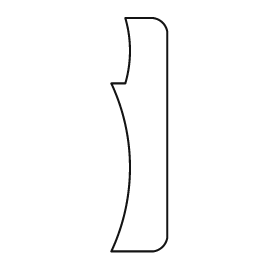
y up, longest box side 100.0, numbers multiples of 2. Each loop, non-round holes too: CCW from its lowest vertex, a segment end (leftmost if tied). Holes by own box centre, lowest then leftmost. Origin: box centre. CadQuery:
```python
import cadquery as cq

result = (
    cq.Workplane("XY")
    .moveTo(-12.0, -50.0)
    .lineTo(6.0, -50.0)
    .threePointArc((10.0, -48.0), (12.0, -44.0))
    .lineTo(12.0, 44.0)
    .threePointArc((10.0, 48.0), (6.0, 50.0))
    .lineTo(-6.0, 50.0)
    .threePointArc((-4.0, 36.0), (-6.0, 22.0))
    .lineTo(-12.0, 22.0)
    .threePointArc((-4.0, -14.0), (-12.0, -50.0))
    .close()
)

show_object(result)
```